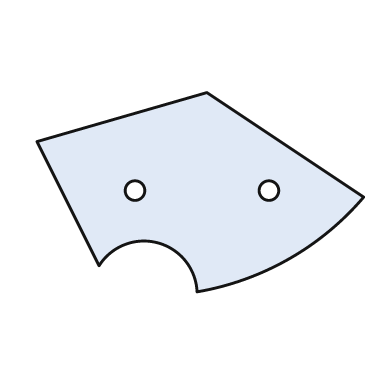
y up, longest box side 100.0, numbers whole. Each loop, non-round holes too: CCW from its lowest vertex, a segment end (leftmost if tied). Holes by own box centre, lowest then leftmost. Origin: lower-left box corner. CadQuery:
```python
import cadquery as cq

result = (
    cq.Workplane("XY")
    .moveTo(49.0, 0.0)
    .threePointArc((77.0, 10.0), (100.0, 29.0))
    .lineTo(52.0, 61.0)
    .lineTo(0.0, 46.0)
    .lineTo(19.0, 8.0)
    .threePointArc((37.0, 15.0), (49.0, 0.0))
    .close()
    .moveTo(30.0, 31.0)
    .circle(3.0)
    .moveTo(71.0, 31.0)
    .circle(3.0)
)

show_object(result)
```